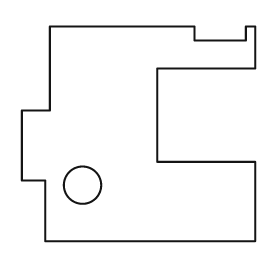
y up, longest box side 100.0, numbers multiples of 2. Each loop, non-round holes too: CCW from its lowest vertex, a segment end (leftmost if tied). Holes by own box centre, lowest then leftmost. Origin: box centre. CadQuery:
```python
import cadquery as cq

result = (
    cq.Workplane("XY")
    .moveTo(-40.0, -46.0)
    .lineTo(50.0, -46.0)
    .lineTo(50.0, -12.0)
    .lineTo(8.0, -12.0)
    .lineTo(8.0, 28.0)
    .lineTo(50.0, 28.0)
    .lineTo(50.0, 46.0)
    .lineTo(46.0, 46.0)
    .lineTo(46.0, 40.0)
    .lineTo(24.0, 40.0)
    .lineTo(24.0, 46.0)
    .lineTo(-38.0, 46.0)
    .lineTo(-38.0, 10.0)
    .lineTo(-50.0, 10.0)
    .lineTo(-50.0, -20.0)
    .lineTo(-40.0, -20.0)
    .close()
    .moveTo(-24.0, -22.0)
    .circle(8.0)
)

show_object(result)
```